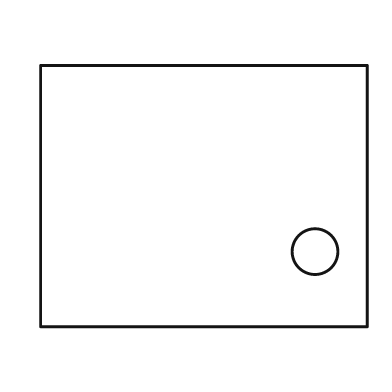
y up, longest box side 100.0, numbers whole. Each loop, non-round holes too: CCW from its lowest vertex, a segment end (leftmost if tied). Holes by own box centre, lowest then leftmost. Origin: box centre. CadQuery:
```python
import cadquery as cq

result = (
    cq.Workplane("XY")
    .moveTo(-50.0, -40.0)
    .lineTo(50.0, -40.0)
    .lineTo(50.0, 40.0)
    .lineTo(-50.0, 40.0)
    .close()
    .moveTo(34.0, -17.0)
    .circle(7.0)
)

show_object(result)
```